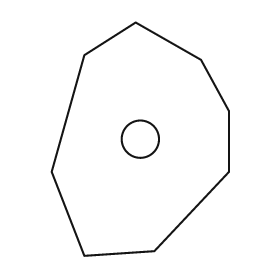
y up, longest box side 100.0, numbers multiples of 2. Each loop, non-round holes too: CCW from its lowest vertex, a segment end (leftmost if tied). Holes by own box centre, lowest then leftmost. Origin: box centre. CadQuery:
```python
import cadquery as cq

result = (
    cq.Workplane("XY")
    .moveTo(-24.0, -50.0)
    .lineTo(6.0, -48.0)
    .lineTo(38.0, -14.0)
    .lineTo(38.0, 12.0)
    .lineTo(26.0, 34.0)
    .lineTo(-2.0, 50.0)
    .lineTo(-24.0, 36.0)
    .lineTo(-38.0, -14.0)
    .close()
    .moveTo(0.0, 0.0)
    .circle(8.0)
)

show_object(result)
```